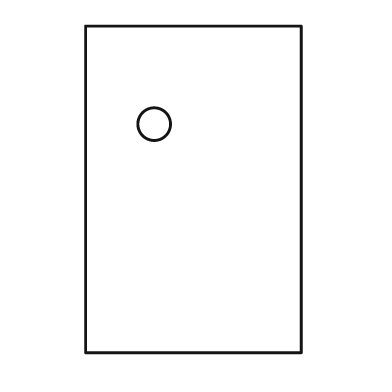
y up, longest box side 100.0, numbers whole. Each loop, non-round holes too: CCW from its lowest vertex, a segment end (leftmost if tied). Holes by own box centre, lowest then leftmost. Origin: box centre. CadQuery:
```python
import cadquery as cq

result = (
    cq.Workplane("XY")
    .moveTo(-33.0, -50.0)
    .lineTo(33.0, -50.0)
    .lineTo(33.0, 50.0)
    .lineTo(-33.0, 50.0)
    .close()
    .moveTo(-12.0, 20.0)
    .circle(5.0)
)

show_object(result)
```